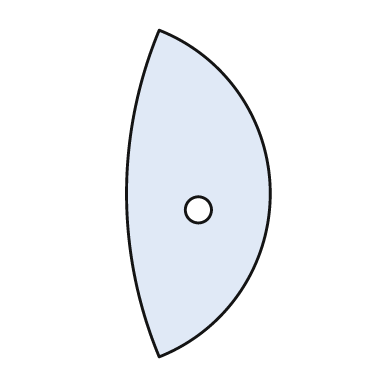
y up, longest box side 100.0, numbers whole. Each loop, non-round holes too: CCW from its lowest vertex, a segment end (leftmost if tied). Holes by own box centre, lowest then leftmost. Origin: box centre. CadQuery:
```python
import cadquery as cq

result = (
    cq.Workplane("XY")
    .moveTo(-12.0, -50.0)
    .threePointArc((22.0, 0.0), (-12.0, 50.0))
    .threePointArc((-22.0, 0.0), (-12.0, -50.0))
    .close()
    .moveTo(0.0, -5.0)
    .circle(4.0)
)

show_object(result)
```